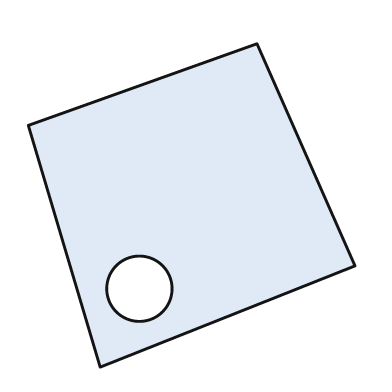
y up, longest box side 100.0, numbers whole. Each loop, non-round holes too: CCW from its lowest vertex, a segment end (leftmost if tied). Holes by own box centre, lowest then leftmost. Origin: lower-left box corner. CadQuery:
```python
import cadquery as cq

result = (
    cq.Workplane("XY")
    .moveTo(22.0, 0.0)
    .lineTo(100.0, 31.0)
    .lineTo(70.0, 99.0)
    .lineTo(0.0, 74.0)
    .close()
    .moveTo(34.0, 24.0)
    .circle(10.0)
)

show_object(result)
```